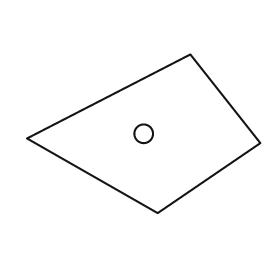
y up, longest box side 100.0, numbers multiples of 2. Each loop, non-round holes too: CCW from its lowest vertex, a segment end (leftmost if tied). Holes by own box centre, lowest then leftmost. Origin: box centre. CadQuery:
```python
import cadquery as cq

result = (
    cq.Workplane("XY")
    .moveTo(6.0, -34.0)
    .lineTo(50.0, -4.0)
    .lineTo(20.0, 34.0)
    .lineTo(-50.0, -2.0)
    .close()
    .moveTo(0.0, 0.0)
    .circle(4.0)
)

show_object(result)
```